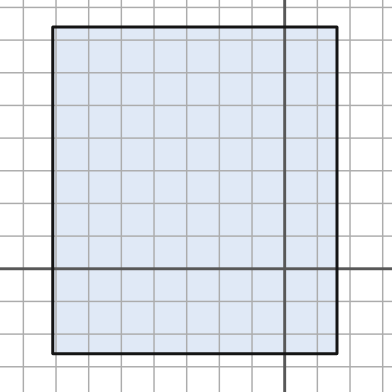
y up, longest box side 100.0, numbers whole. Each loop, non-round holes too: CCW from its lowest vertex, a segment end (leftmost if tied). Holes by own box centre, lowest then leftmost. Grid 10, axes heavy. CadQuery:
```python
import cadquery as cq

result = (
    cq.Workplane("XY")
    .moveTo(-71.0, -26.0)
    .lineTo(16.0, -26.0)
    .lineTo(16.0, 74.0)
    .lineTo(-71.0, 74.0)
    .close()
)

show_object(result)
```